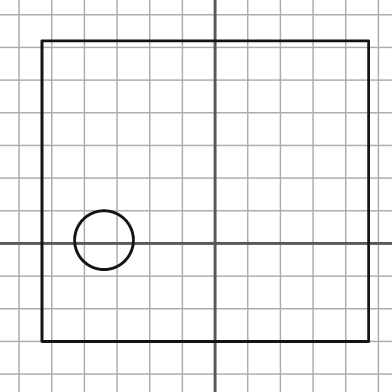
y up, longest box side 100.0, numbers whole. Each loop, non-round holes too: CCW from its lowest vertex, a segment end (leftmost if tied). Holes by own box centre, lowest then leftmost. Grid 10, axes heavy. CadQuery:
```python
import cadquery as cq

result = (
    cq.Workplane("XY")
    .moveTo(-53.0, -30.0)
    .lineTo(47.0, -30.0)
    .lineTo(47.0, 62.0)
    .lineTo(-53.0, 62.0)
    .close()
    .moveTo(-34.0, 1.0)
    .circle(9.0)
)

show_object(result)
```